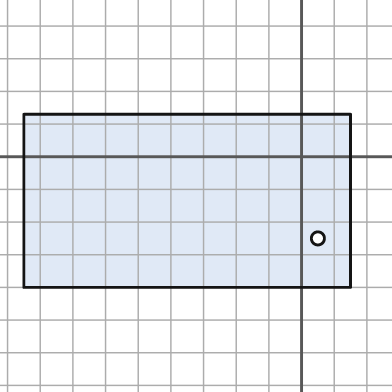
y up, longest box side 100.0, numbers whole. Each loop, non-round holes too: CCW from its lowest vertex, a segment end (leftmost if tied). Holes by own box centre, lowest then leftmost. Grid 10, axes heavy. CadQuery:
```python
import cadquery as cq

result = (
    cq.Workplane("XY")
    .moveTo(-85.0, -40.0)
    .lineTo(15.0, -40.0)
    .lineTo(15.0, 13.0)
    .lineTo(-85.0, 13.0)
    .close()
    .moveTo(5.0, -25.0)
    .circle(2.0)
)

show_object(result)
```